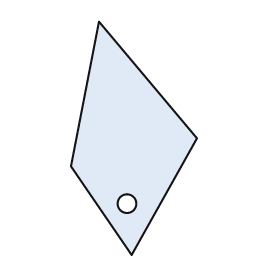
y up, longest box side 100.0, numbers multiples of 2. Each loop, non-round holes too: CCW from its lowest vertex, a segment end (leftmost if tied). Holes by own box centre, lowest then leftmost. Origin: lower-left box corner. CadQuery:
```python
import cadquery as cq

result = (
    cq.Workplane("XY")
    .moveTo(26.0, 0.0)
    .lineTo(54.0, 50.0)
    .lineTo(12.0, 100.0)
    .lineTo(0.0, 38.0)
    .close()
    .moveTo(24.0, 22.0)
    .circle(4.0)
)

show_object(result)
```